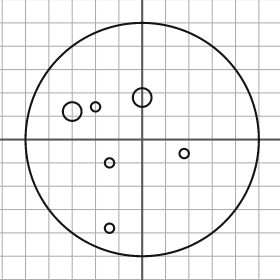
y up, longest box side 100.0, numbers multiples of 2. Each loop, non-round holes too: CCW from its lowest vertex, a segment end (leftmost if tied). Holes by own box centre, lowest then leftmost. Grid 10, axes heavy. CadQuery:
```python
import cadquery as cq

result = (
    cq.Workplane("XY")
    .moveTo(0.0, 0.0)
    .circle(50.0)
    .moveTo(-14.0, -38.0)
    .circle(2.0)
    .moveTo(-14.0, -10.0)
    .circle(2.0)
    .moveTo(18.0, -6.0)
    .circle(2.0)
    .moveTo(-30.0, 12.0)
    .circle(4.0)
    .moveTo(-20.0, 14.0)
    .circle(2.0)
    .moveTo(0.0, 18.0)
    .circle(4.0)
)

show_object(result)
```